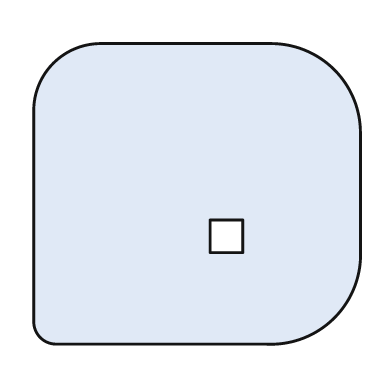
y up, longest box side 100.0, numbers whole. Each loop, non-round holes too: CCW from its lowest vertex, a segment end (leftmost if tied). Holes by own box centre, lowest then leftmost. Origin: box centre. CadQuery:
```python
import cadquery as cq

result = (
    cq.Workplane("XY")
    .moveTo(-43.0, -46.0)
    .lineTo(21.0, -46.0)
    .threePointArc((42.0, -38.0), (50.0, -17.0))
    .lineTo(50.0, 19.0)
    .threePointArc((42.0, 38.0), (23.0, 46.0))
    .lineTo(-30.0, 46.0)
    .threePointArc((-44.0, 40.0), (-50.0, 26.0))
    .lineTo(-50.0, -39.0)
    .threePointArc((-48.0, -44.0), (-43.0, -46.0))
    .close()
    .moveTo(4.0, -18.0)
    .lineTo(14.0, -18.0)
    .lineTo(14.0, -8.0)
    .lineTo(4.0, -8.0)
    .close()
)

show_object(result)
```